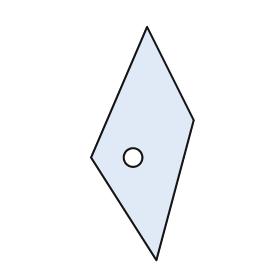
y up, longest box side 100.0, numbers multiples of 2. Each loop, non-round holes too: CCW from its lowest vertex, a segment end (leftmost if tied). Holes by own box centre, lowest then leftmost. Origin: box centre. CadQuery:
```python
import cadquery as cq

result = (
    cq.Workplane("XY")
    .moveTo(6.0, -50.0)
    .lineTo(22.0, 10.0)
    .lineTo(2.0, 50.0)
    .lineTo(-22.0, -6.0)
    .close()
    .moveTo(-4.0, -6.0)
    .circle(4.0)
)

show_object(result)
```